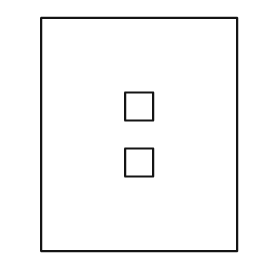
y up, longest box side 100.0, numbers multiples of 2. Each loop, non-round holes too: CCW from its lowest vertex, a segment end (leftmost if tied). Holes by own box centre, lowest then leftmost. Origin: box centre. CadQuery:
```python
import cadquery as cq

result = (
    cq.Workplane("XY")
    .moveTo(-42.0, -50.0)
    .lineTo(42.0, -50.0)
    .lineTo(42.0, 50.0)
    .lineTo(-42.0, 50.0)
    .close()
    .moveTo(-6.0, -18.0)
    .lineTo(6.0, -18.0)
    .lineTo(6.0, -6.0)
    .lineTo(-6.0, -6.0)
    .close()
    .moveTo(-6.0, 6.0)
    .lineTo(6.0, 6.0)
    .lineTo(6.0, 18.0)
    .lineTo(-6.0, 18.0)
    .close()
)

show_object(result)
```